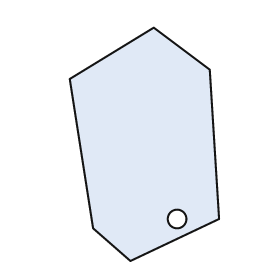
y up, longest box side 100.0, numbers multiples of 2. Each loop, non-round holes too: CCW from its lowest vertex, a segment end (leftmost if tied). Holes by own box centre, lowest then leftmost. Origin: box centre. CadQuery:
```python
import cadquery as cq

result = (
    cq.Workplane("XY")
    .moveTo(-6.0, -50.0)
    .lineTo(32.0, -32.0)
    .lineTo(28.0, 32.0)
    .lineTo(4.0, 50.0)
    .lineTo(-32.0, 28.0)
    .lineTo(-22.0, -36.0)
    .close()
    .moveTo(14.0, -32.0)
    .circle(4.0)
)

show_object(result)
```